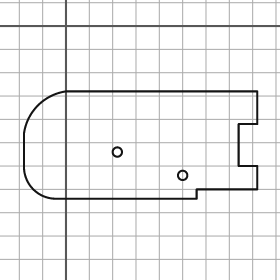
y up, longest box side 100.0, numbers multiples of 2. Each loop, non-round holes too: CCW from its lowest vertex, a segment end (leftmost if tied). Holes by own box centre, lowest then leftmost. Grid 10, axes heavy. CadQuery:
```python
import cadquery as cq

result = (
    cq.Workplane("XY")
    .moveTo(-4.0, -74.0)
    .lineTo(56.0, -74.0)
    .lineTo(56.0, -70.0)
    .lineTo(82.0, -70.0)
    .lineTo(82.0, -60.0)
    .lineTo(74.0, -60.0)
    .lineTo(74.0, -42.0)
    .lineTo(82.0, -42.0)
    .lineTo(82.0, -28.0)
    .lineTo(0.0, -28.0)
    .threePointArc((-12.0, -34.0), (-18.0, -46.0))
    .lineTo(-18.0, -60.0)
    .threePointArc((-14.0, -70.0), (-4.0, -74.0))
    .close()
    .moveTo(50.0, -64.0)
    .circle(2.0)
    .moveTo(22.0, -54.0)
    .circle(2.0)
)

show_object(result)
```